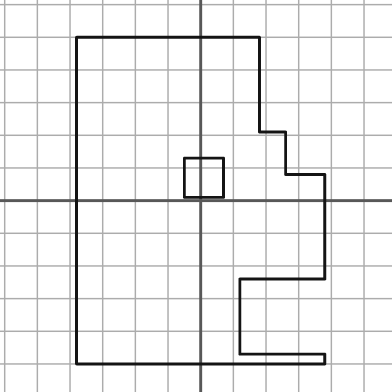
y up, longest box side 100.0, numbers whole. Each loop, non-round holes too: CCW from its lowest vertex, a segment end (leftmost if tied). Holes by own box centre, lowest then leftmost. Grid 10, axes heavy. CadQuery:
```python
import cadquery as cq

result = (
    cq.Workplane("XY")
    .moveTo(-38.0, -50.0)
    .lineTo(38.0, -50.0)
    .lineTo(38.0, -47.0)
    .lineTo(12.0, -47.0)
    .lineTo(12.0, -24.0)
    .lineTo(38.0, -24.0)
    .lineTo(38.0, 8.0)
    .lineTo(26.0, 8.0)
    .lineTo(26.0, 21.0)
    .lineTo(18.0, 21.0)
    .lineTo(18.0, 50.0)
    .lineTo(-38.0, 50.0)
    .close()
    .moveTo(-5.0, 1.0)
    .lineTo(7.0, 1.0)
    .lineTo(7.0, 13.0)
    .lineTo(-5.0, 13.0)
    .close()
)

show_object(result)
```